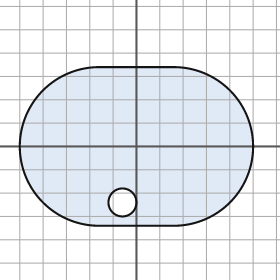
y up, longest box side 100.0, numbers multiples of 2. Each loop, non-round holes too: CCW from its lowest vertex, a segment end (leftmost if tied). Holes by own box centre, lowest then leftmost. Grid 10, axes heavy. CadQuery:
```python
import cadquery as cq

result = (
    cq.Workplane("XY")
    .moveTo(-16.0, -34.0)
    .lineTo(16.0, -34.0)
    .threePointArc((50.0, 0.0), (16.0, 34.0))
    .lineTo(-16.0, 34.0)
    .threePointArc((-50.0, 0.0), (-16.0, -34.0))
    .close()
    .moveTo(-6.0, -24.0)
    .circle(6.0)
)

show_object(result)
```